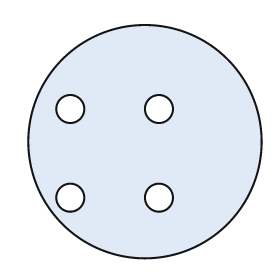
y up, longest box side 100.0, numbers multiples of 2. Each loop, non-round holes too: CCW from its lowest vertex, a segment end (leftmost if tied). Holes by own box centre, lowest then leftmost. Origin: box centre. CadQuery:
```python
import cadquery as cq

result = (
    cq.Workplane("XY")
    .moveTo(0.0, 0.0)
    .circle(50.0)
    .moveTo(-32.0, -24.0)
    .circle(6.0)
    .moveTo(6.0, -24.0)
    .circle(6.0)
    .moveTo(-32.0, 14.0)
    .circle(6.0)
    .moveTo(6.0, 14.0)
    .circle(6.0)
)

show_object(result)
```